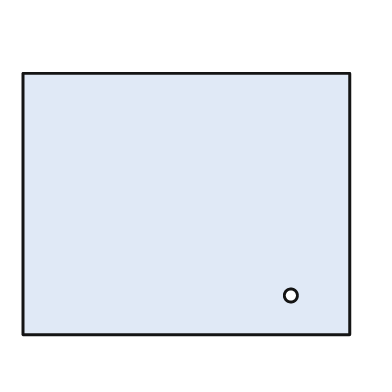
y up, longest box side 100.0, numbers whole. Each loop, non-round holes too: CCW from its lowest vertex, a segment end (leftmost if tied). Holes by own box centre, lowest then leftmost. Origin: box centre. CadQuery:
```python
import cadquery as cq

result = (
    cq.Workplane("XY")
    .moveTo(-50.0, -40.0)
    .lineTo(50.0, -40.0)
    .lineTo(50.0, 40.0)
    .lineTo(-50.0, 40.0)
    .close()
    .moveTo(32.0, -28.0)
    .circle(2.0)
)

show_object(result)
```